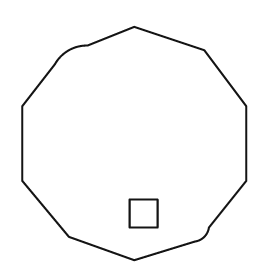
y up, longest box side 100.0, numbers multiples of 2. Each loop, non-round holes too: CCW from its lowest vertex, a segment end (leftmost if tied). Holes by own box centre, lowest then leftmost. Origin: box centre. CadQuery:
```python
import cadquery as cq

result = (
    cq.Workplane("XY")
    .moveTo(0.0, -50.0)
    .lineTo(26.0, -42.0)
    .threePointArc((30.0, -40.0), (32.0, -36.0))
    .lineTo(48.0, -16.0)
    .lineTo(48.0, 16.0)
    .lineTo(30.0, 40.0)
    .lineTo(0.0, 50.0)
    .lineTo(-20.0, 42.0)
    .threePointArc((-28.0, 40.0), (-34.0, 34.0))
    .lineTo(-48.0, 16.0)
    .lineTo(-48.0, -16.0)
    .lineTo(-28.0, -40.0)
    .close()
    .moveTo(-2.0, -36.0)
    .lineTo(10.0, -36.0)
    .lineTo(10.0, -24.0)
    .lineTo(-2.0, -24.0)
    .close()
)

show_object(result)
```